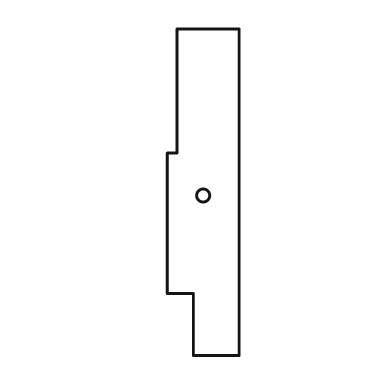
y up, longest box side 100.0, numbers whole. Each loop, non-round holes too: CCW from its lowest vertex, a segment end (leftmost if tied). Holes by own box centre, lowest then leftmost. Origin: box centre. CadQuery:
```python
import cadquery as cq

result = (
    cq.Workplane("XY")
    .moveTo(-3.0, -50.0)
    .lineTo(11.0, -50.0)
    .lineTo(11.0, 50.0)
    .lineTo(-8.0, 50.0)
    .lineTo(-8.0, 12.0)
    .lineTo(-11.0, 12.0)
    .lineTo(-11.0, -31.0)
    .lineTo(-3.0, -31.0)
    .close()
    .moveTo(0.0, -1.0)
    .circle(2.0)
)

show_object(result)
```